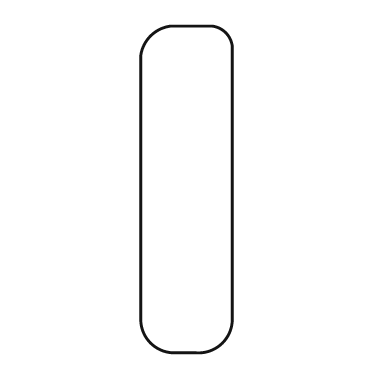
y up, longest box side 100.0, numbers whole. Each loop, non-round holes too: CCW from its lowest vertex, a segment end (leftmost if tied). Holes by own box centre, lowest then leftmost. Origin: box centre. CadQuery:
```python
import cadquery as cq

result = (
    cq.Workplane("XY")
    .moveTo(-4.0, -50.0)
    .lineTo(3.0, -50.0)
    .threePointArc((11.0, -47.0), (14.0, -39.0))
    .lineTo(14.0, 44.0)
    .threePointArc((12.0, 48.0), (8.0, 50.0))
    .lineTo(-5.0, 50.0)
    .threePointArc((-11.0, 47.0), (-14.0, 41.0))
    .lineTo(-14.0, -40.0)
    .threePointArc((-11.0, -47.0), (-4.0, -50.0))
    .close()
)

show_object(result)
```